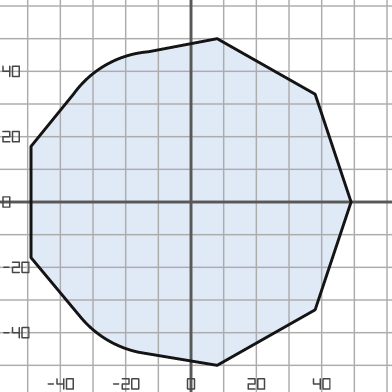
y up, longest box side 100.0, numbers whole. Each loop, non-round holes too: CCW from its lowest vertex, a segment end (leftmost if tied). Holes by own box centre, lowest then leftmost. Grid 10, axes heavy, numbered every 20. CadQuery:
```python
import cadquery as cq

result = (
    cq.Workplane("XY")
    .moveTo(8.0, -50.0)
    .lineTo(38.0, -33.0)
    .lineTo(49.0, 0.0)
    .lineTo(38.0, 33.0)
    .lineTo(8.0, 50.0)
    .lineTo(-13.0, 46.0)
    .threePointArc((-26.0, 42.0), (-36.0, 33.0))
    .lineTo(-49.0, 17.0)
    .lineTo(-49.0, -17.0)
    .lineTo(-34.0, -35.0)
    .threePointArc((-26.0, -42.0), (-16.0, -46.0))
    .close()
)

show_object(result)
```